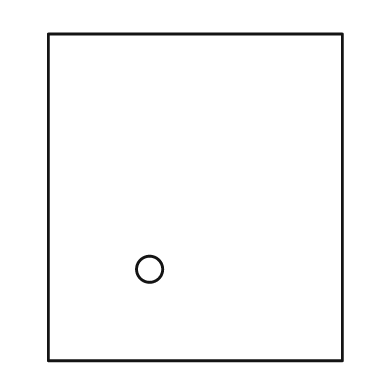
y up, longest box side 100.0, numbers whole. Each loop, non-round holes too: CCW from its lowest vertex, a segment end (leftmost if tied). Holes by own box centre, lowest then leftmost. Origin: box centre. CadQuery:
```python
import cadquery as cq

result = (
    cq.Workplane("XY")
    .moveTo(-45.0, -50.0)
    .lineTo(45.0, -50.0)
    .lineTo(45.0, 50.0)
    .lineTo(-45.0, 50.0)
    .close()
    .moveTo(-14.0, -22.0)
    .circle(4.0)
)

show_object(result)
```